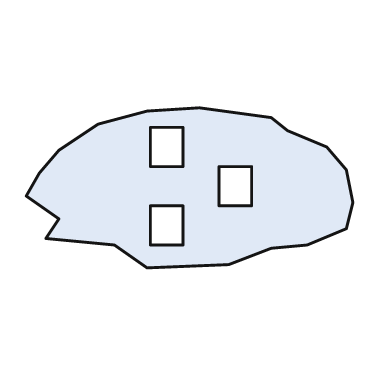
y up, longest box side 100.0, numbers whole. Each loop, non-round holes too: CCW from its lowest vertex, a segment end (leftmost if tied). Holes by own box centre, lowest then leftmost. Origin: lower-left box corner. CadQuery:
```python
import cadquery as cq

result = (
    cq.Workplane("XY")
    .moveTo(37.0, 0.0)
    .lineTo(62.0, 1.0)
    .lineTo(75.0, 6.0)
    .lineTo(86.0, 7.0)
    .lineTo(98.0, 12.0)
    .lineTo(100.0, 20.0)
    .lineTo(98.0, 30.0)
    .lineTo(92.0, 37.0)
    .lineTo(80.0, 42.0)
    .lineTo(75.0, 46.0)
    .lineTo(53.0, 49.0)
    .lineTo(37.0, 48.0)
    .lineTo(22.0, 44.0)
    .lineTo(10.0, 36.0)
    .lineTo(4.0, 29.0)
    .lineTo(0.0, 22.0)
    .lineTo(10.0, 15.0)
    .lineTo(6.0, 9.0)
    .lineTo(27.0, 7.0)
    .close()
    .moveTo(38.0, 7.0)
    .lineTo(48.0, 7.0)
    .lineTo(48.0, 19.0)
    .lineTo(38.0, 19.0)
    .close()
    .moveTo(59.0, 19.0)
    .lineTo(69.0, 19.0)
    .lineTo(69.0, 31.0)
    .lineTo(59.0, 31.0)
    .close()
    .moveTo(38.0, 31.0)
    .lineTo(48.0, 31.0)
    .lineTo(48.0, 43.0)
    .lineTo(38.0, 43.0)
    .close()
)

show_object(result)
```